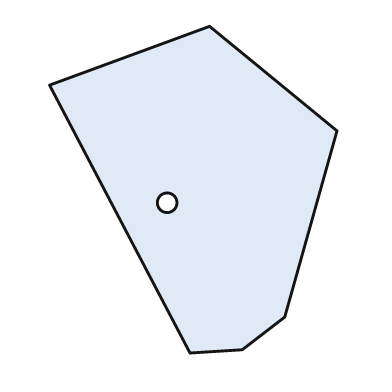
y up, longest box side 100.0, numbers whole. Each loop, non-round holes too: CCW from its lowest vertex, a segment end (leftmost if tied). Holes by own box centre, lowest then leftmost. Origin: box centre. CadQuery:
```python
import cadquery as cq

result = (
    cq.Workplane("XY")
    .moveTo(-1.0, -50.0)
    .lineTo(15.0, -49.0)
    .lineTo(28.0, -39.0)
    .lineTo(44.0, 18.0)
    .lineTo(5.0, 50.0)
    .lineTo(-44.0, 32.0)
    .close()
    .moveTo(-8.0, -4.0)
    .circle(3.0)
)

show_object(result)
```